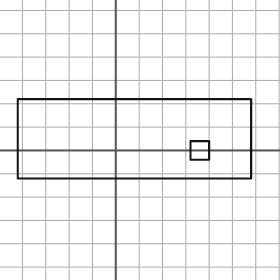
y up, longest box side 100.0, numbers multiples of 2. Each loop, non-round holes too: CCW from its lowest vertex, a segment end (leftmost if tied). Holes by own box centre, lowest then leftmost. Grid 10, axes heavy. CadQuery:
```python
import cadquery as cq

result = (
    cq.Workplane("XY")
    .moveTo(-42.0, -12.0)
    .lineTo(58.0, -12.0)
    .lineTo(58.0, 22.0)
    .lineTo(-42.0, 22.0)
    .close()
    .moveTo(32.0, -4.0)
    .lineTo(40.0, -4.0)
    .lineTo(40.0, 4.0)
    .lineTo(32.0, 4.0)
    .close()
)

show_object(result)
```